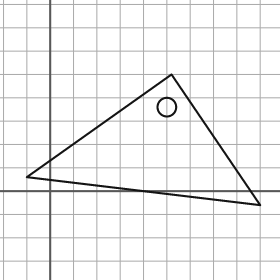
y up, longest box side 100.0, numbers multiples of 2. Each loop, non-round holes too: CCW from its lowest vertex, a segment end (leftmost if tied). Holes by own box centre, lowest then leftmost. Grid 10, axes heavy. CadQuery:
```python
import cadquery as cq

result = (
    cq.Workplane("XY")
    .moveTo(90.0, -6.0)
    .lineTo(52.0, 50.0)
    .lineTo(-10.0, 6.0)
    .close()
    .moveTo(50.0, 36.0)
    .circle(4.0)
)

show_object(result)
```